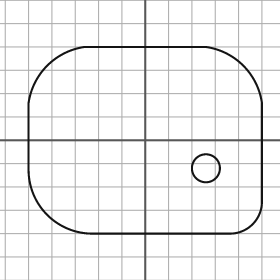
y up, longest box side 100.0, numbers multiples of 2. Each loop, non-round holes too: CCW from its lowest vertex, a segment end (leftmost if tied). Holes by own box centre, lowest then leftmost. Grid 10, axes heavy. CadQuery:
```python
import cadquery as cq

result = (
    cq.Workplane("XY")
    .moveTo(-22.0, -40.0)
    .lineTo(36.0, -40.0)
    .threePointArc((46.0, -36.0), (50.0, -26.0))
    .lineTo(50.0, 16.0)
    .threePointArc((42.0, 32.0), (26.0, 40.0))
    .lineTo(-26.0, 40.0)
    .threePointArc((-42.0, 32.0), (-50.0, 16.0))
    .lineTo(-50.0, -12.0)
    .threePointArc((-42.0, -32.0), (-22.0, -40.0))
    .close()
    .moveTo(26.0, -12.0)
    .circle(6.0)
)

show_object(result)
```